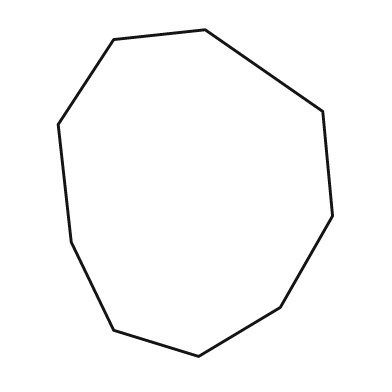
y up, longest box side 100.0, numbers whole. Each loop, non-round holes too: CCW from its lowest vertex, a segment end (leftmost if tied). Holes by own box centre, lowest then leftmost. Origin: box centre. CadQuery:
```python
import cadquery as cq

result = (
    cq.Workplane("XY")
    .moveTo(1.0, -50.0)
    .lineTo(26.0, -35.0)
    .lineTo(42.0, -7.0)
    .lineTo(39.0, 25.0)
    .lineTo(3.0, 50.0)
    .lineTo(-25.0, 47.0)
    .lineTo(-42.0, 21.0)
    .lineTo(-38.0, -15.0)
    .lineTo(-25.0, -42.0)
    .close()
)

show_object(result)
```